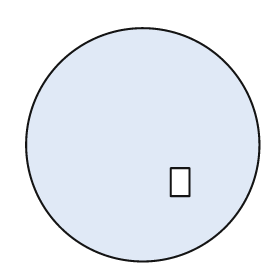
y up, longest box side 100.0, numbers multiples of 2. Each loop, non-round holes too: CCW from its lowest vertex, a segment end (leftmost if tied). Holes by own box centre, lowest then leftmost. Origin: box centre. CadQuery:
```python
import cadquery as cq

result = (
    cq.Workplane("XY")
    .moveTo(0.0, 0.0)
    .circle(50.0)
    .moveTo(12.0, -22.0)
    .lineTo(20.0, -22.0)
    .lineTo(20.0, -10.0)
    .lineTo(12.0, -10.0)
    .close()
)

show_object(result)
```